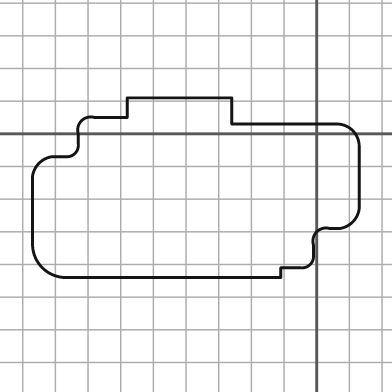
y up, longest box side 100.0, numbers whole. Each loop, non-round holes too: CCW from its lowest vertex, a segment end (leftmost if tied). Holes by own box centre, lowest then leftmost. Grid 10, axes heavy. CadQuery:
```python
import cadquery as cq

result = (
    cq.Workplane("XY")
    .moveTo(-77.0, -44.0)
    .lineTo(-11.0, -44.0)
    .lineTo(-11.0, -41.0)
    .lineTo(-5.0, -41.0)
    .threePointArc((-2.0, -40.0), (-1.0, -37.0))
    .lineTo(-1.0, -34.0)
    .threePointArc((0.0, -30.0), (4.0, -29.0))
    .lineTo(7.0, -29.0)
    .threePointArc((11.0, -27.0), (13.0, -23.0))
    .lineTo(13.0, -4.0)
    .threePointArc((11.0, 1.0), (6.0, 3.0))
    .lineTo(-26.0, 3.0)
    .lineTo(-26.0, 11.0)
    .lineTo(-58.0, 11.0)
    .lineTo(-58.0, 5.0)
    .lineTo(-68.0, 5.0)
    .threePointArc((-72.0, 4.0), (-73.0, 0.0))
    .lineTo(-73.0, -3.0)
    .threePointArc((-74.0, -6.0), (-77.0, -7.0))
    .lineTo(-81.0, -7.0)
    .threePointArc((-85.0, -9.0), (-87.0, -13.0))
    .lineTo(-87.0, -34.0)
    .threePointArc((-84.0, -41.0), (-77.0, -44.0))
    .close()
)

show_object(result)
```